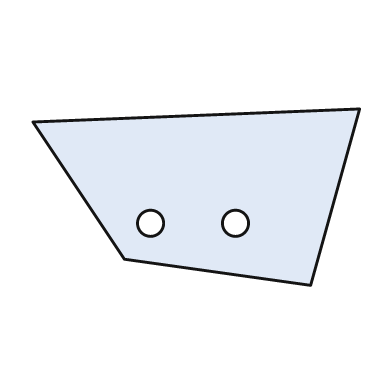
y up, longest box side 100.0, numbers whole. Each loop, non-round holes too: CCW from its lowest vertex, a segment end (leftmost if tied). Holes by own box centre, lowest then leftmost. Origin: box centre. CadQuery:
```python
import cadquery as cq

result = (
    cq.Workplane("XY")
    .moveTo(35.0, -27.0)
    .lineTo(50.0, 27.0)
    .lineTo(-50.0, 23.0)
    .lineTo(-22.0, -19.0)
    .close()
    .moveTo(-14.0, -8.0)
    .circle(4.0)
    .moveTo(12.0, -8.0)
    .circle(4.0)
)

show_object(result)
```